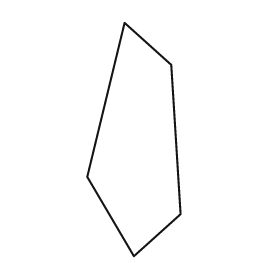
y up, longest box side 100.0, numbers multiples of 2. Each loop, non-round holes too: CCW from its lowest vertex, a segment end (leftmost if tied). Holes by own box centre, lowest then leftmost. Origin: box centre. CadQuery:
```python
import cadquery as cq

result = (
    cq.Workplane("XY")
    .moveTo(0.0, -50.0)
    .lineTo(20.0, -32.0)
    .lineTo(16.0, 32.0)
    .lineTo(-4.0, 50.0)
    .lineTo(-20.0, -16.0)
    .close()
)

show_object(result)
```